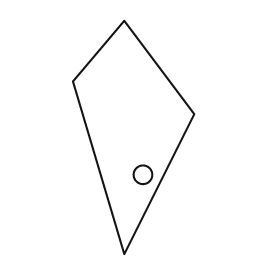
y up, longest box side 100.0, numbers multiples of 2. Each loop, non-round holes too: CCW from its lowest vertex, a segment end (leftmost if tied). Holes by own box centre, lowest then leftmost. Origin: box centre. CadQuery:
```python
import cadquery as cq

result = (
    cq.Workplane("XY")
    .moveTo(-4.0, -50.0)
    .lineTo(26.0, 10.0)
    .lineTo(-4.0, 50.0)
    .lineTo(-26.0, 24.0)
    .close()
    .moveTo(4.0, -16.0)
    .circle(4.0)
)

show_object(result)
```